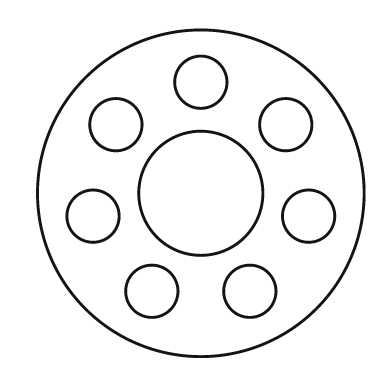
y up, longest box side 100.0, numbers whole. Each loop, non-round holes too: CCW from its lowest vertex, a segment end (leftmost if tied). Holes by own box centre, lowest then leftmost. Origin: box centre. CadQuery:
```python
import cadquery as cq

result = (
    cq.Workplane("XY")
    .moveTo(0.0, 0.0)
    .circle(50.0)
    .moveTo(-15.0, -30.0)
    .circle(8.0)
    .moveTo(15.0, -30.0)
    .circle(8.0)
    .moveTo(-33.0, -7.0)
    .circle(8.0)
    .moveTo(33.0, -7.0)
    .circle(8.0)
    .moveTo(0.0, 0.0)
    .circle(19.0)
    .moveTo(-26.0, 21.0)
    .circle(8.0)
    .moveTo(26.0, 21.0)
    .circle(8.0)
    .moveTo(0.0, 34.0)
    .circle(8.0)
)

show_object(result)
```